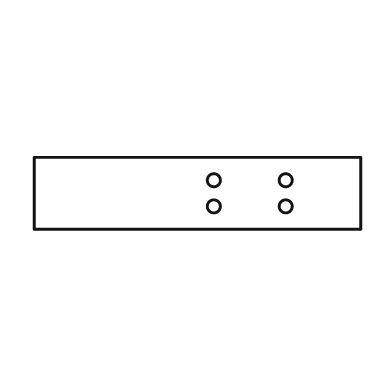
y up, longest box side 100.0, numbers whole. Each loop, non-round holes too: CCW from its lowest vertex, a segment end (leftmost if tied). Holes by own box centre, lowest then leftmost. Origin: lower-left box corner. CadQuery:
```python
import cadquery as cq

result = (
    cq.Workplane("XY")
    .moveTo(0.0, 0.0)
    .lineTo(100.0, 0.0)
    .lineTo(100.0, 22.0)
    .lineTo(0.0, 22.0)
    .close()
    .moveTo(55.0, 7.0)
    .circle(2.0)
    .moveTo(77.0, 7.0)
    .circle(2.0)
    .moveTo(55.0, 15.0)
    .circle(2.0)
    .moveTo(77.0, 15.0)
    .circle(2.0)
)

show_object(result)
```